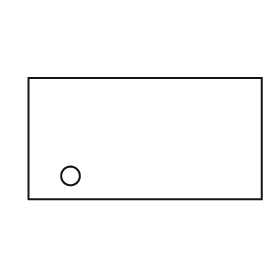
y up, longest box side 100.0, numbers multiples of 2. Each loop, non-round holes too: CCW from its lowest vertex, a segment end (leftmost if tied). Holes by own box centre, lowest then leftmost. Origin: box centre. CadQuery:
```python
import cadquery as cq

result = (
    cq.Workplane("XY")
    .moveTo(-50.0, -26.0)
    .lineTo(50.0, -26.0)
    .lineTo(50.0, 26.0)
    .lineTo(-50.0, 26.0)
    .close()
    .moveTo(-32.0, -16.0)
    .circle(4.0)
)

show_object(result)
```